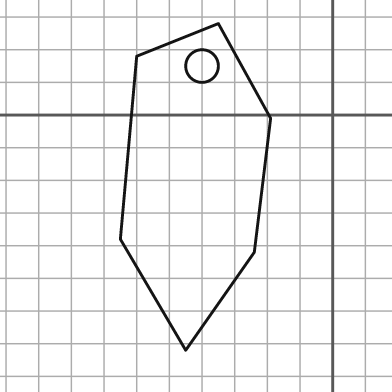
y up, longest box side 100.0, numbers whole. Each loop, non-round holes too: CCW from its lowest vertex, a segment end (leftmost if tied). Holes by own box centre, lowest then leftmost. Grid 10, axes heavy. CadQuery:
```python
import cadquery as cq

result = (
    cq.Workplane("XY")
    .moveTo(-45.0, -72.0)
    .lineTo(-24.0, -42.0)
    .lineTo(-19.0, -1.0)
    .lineTo(-35.0, 28.0)
    .lineTo(-60.0, 18.0)
    .lineTo(-65.0, -38.0)
    .close()
    .moveTo(-40.0, 15.0)
    .circle(5.0)
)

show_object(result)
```